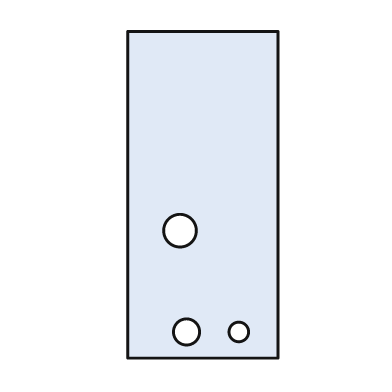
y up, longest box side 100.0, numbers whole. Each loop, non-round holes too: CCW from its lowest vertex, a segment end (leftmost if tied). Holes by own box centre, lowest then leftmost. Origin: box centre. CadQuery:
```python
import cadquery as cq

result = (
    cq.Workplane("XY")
    .moveTo(-23.0, -50.0)
    .lineTo(23.0, -50.0)
    .lineTo(23.0, 50.0)
    .lineTo(-23.0, 50.0)
    .close()
    .moveTo(-5.0, -42.0)
    .circle(4.0)
    .moveTo(11.0, -42.0)
    .circle(3.0)
    .moveTo(-7.0, -11.0)
    .circle(5.0)
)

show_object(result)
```